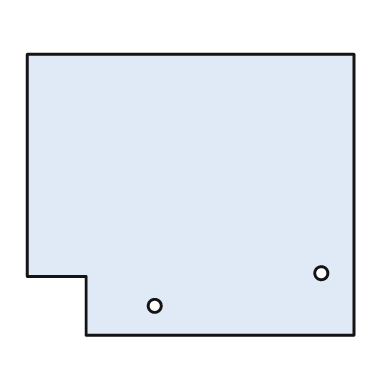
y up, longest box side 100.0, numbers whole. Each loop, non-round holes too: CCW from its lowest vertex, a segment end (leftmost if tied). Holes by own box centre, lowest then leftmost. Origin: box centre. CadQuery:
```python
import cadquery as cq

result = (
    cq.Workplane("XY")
    .moveTo(-32.0, -43.0)
    .lineTo(50.0, -43.0)
    .lineTo(50.0, 43.0)
    .lineTo(-50.0, 43.0)
    .lineTo(-50.0, -25.0)
    .lineTo(-32.0, -25.0)
    .close()
    .moveTo(-11.0, -34.0)
    .circle(2.0)
    .moveTo(40.0, -24.0)
    .circle(2.0)
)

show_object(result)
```